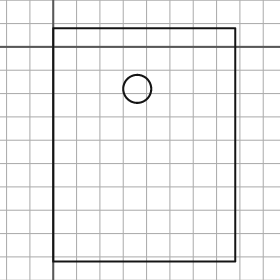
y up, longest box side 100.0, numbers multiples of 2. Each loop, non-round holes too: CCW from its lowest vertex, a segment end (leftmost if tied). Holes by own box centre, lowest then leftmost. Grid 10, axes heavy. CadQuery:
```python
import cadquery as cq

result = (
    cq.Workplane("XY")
    .moveTo(0.0, -92.0)
    .lineTo(78.0, -92.0)
    .lineTo(78.0, 8.0)
    .lineTo(0.0, 8.0)
    .close()
    .moveTo(36.0, -18.0)
    .circle(6.0)
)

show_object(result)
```